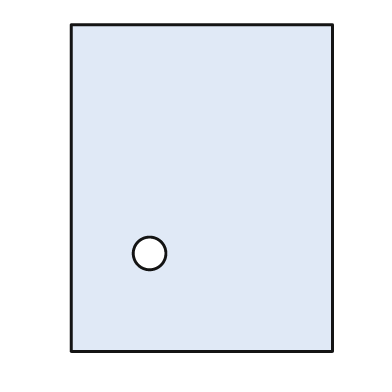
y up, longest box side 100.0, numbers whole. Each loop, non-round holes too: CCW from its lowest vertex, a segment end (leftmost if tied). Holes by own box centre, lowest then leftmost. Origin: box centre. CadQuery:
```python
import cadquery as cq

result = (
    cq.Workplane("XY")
    .moveTo(-40.0, -50.0)
    .lineTo(40.0, -50.0)
    .lineTo(40.0, 50.0)
    .lineTo(-40.0, 50.0)
    .close()
    .moveTo(-16.0, -20.0)
    .circle(5.0)
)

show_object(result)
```